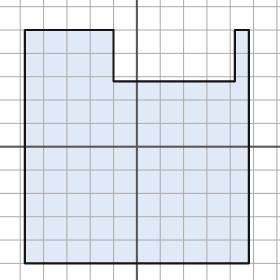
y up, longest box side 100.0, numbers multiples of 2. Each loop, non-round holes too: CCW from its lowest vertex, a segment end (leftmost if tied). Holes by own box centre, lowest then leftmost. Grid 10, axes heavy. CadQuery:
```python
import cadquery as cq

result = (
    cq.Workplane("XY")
    .moveTo(-48.0, -50.0)
    .lineTo(48.0, -50.0)
    .lineTo(48.0, 50.0)
    .lineTo(42.0, 50.0)
    .lineTo(42.0, 28.0)
    .lineTo(-10.0, 28.0)
    .lineTo(-10.0, 50.0)
    .lineTo(-48.0, 50.0)
    .close()
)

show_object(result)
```